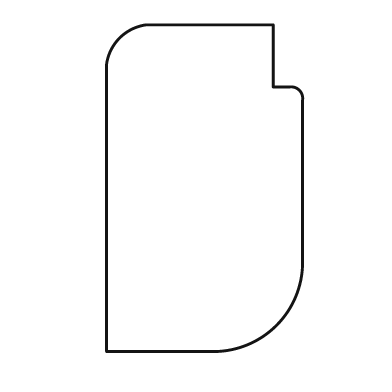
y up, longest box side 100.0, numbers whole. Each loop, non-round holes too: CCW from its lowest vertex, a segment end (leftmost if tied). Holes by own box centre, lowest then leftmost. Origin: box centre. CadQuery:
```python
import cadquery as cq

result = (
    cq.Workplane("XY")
    .moveTo(-30.0, -50.0)
    .lineTo(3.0, -50.0)
    .threePointArc((22.0, -42.0), (30.0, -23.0))
    .lineTo(30.0, 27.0)
    .threePointArc((29.0, 30.0), (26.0, 31.0))
    .lineTo(21.0, 31.0)
    .lineTo(21.0, 50.0)
    .lineTo(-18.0, 50.0)
    .threePointArc((-26.0, 46.0), (-30.0, 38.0))
    .close()
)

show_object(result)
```